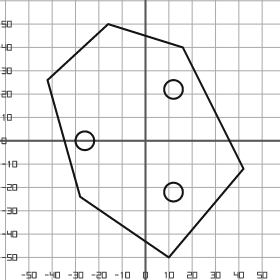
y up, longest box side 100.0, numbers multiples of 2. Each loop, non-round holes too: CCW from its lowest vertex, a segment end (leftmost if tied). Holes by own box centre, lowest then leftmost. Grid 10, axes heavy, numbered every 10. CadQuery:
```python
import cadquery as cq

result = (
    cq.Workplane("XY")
    .moveTo(10.0, -50.0)
    .lineTo(42.0, -12.0)
    .lineTo(16.0, 40.0)
    .lineTo(-16.0, 50.0)
    .lineTo(-42.0, 26.0)
    .lineTo(-28.0, -24.0)
    .close()
    .moveTo(12.0, -22.0)
    .circle(4.0)
    .moveTo(-26.0, 0.0)
    .circle(4.0)
    .moveTo(12.0, 22.0)
    .circle(4.0)
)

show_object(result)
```